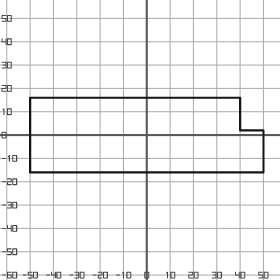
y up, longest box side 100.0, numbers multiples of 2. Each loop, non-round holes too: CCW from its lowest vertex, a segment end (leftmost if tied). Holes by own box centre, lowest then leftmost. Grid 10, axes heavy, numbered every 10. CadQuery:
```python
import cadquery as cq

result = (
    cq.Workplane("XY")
    .moveTo(-50.0, -16.0)
    .lineTo(50.0, -16.0)
    .lineTo(50.0, 2.0)
    .lineTo(40.0, 2.0)
    .lineTo(40.0, 16.0)
    .lineTo(-50.0, 16.0)
    .close()
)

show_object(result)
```